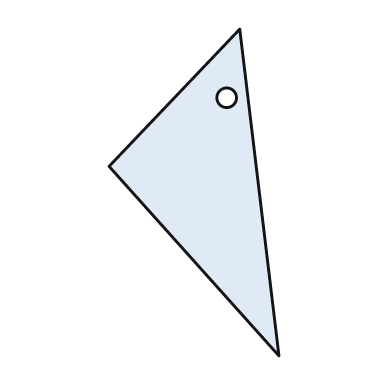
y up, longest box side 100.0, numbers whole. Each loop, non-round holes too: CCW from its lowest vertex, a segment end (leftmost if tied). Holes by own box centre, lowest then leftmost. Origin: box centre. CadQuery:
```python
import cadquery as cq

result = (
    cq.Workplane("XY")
    .moveTo(26.0, -50.0)
    .lineTo(14.0, 50.0)
    .lineTo(-26.0, 8.0)
    .close()
    .moveTo(10.0, 29.0)
    .circle(3.0)
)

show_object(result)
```